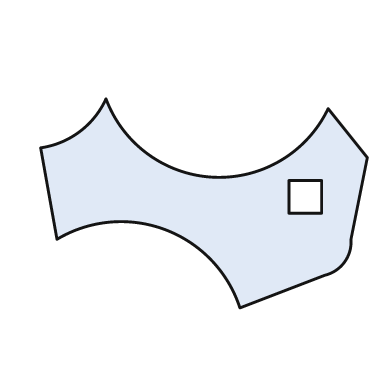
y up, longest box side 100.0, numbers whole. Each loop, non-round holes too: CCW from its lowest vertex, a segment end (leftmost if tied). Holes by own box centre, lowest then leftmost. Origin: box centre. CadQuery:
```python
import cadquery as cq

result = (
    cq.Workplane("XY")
    .moveTo(11.0, -32.0)
    .lineTo(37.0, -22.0)
    .threePointArc((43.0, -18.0), (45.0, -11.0))
    .lineTo(50.0, 14.0)
    .lineTo(38.0, 29.0)
    .threePointArc((3.0, 8.0), (-30.0, 32.0))
    .threePointArc((-38.0, 22.0), (-50.0, 17.0))
    .lineTo(-45.0, -11.0)
    .threePointArc((-12.0, -8.0), (11.0, -32.0))
    .close()
    .moveTo(26.0, -3.0)
    .lineTo(36.0, -3.0)
    .lineTo(36.0, 7.0)
    .lineTo(26.0, 7.0)
    .close()
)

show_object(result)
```